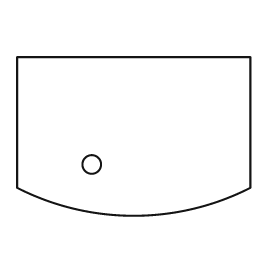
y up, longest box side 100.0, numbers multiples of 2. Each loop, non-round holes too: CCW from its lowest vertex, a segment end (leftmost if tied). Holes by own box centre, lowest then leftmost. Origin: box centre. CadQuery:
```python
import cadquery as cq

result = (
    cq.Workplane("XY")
    .moveTo(-50.0, -22.0)
    .threePointArc((0.0, -34.0), (50.0, -22.0))
    .lineTo(50.0, 34.0)
    .lineTo(-50.0, 34.0)
    .close()
    .moveTo(-18.0, -12.0)
    .circle(4.0)
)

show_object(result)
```